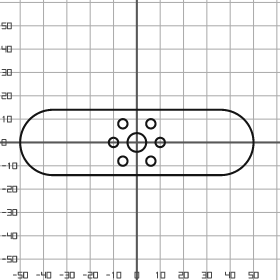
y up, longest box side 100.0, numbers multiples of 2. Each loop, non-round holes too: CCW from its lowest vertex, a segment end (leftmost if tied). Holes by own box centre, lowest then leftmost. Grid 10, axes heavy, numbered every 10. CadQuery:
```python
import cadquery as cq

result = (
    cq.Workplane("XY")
    .moveTo(-36.0, -14.0)
    .lineTo(36.0, -14.0)
    .threePointArc((50.0, 0.0), (36.0, 14.0))
    .lineTo(-36.0, 14.0)
    .threePointArc((-50.0, 0.0), (-36.0, -14.0))
    .close()
    .moveTo(-6.0, -8.0)
    .circle(2.0)
    .moveTo(6.0, -8.0)
    .circle(2.0)
    .moveTo(-10.0, 0.0)
    .circle(2.0)
    .moveTo(0.0, 0.0)
    .circle(4.0)
    .moveTo(10.0, 0.0)
    .circle(2.0)
    .moveTo(-6.0, 8.0)
    .circle(2.0)
    .moveTo(6.0, 8.0)
    .circle(2.0)
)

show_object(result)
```